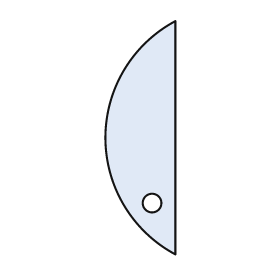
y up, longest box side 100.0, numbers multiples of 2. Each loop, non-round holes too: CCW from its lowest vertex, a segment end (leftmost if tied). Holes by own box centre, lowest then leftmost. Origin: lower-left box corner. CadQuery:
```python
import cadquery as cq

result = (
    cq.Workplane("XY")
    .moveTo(30.0, 0.0)
    .lineTo(30.0, 100.0)
    .threePointArc((0.0, 50.0), (30.0, 0.0))
    .close()
    .moveTo(20.0, 22.0)
    .circle(4.0)
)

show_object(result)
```